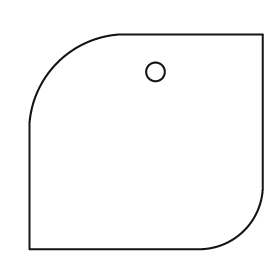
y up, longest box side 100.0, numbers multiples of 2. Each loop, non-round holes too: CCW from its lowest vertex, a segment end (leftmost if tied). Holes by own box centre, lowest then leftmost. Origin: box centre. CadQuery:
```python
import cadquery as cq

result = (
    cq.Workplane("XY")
    .moveTo(-50.0, -46.0)
    .lineTo(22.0, -46.0)
    .threePointArc((42.0, -38.0), (50.0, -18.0))
    .lineTo(50.0, 46.0)
    .lineTo(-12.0, 46.0)
    .threePointArc((-38.0, 34.0), (-50.0, 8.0))
    .close()
    .moveTo(4.0, 30.0)
    .circle(4.0)
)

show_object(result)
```